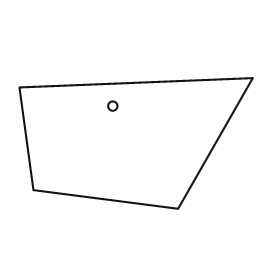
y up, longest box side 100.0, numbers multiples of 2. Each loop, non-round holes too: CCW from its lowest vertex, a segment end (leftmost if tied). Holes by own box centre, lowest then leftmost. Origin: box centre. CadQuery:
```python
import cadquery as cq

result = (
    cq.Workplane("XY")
    .moveTo(18.0, -28.0)
    .lineTo(50.0, 28.0)
    .lineTo(-50.0, 24.0)
    .lineTo(-44.0, -20.0)
    .close()
    .moveTo(-10.0, 16.0)
    .circle(2.0)
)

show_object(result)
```